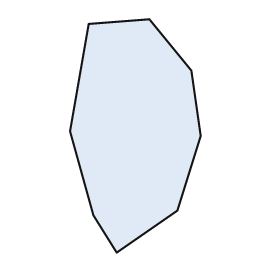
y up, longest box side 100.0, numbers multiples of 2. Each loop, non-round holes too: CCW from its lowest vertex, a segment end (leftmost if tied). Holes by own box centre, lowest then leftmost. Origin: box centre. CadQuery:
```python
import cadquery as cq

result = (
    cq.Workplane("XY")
    .moveTo(-8.0, -50.0)
    .lineTo(18.0, -32.0)
    .lineTo(28.0, 0.0)
    .lineTo(24.0, 28.0)
    .lineTo(6.0, 50.0)
    .lineTo(-20.0, 48.0)
    .lineTo(-28.0, 2.0)
    .lineTo(-18.0, -34.0)
    .close()
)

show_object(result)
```